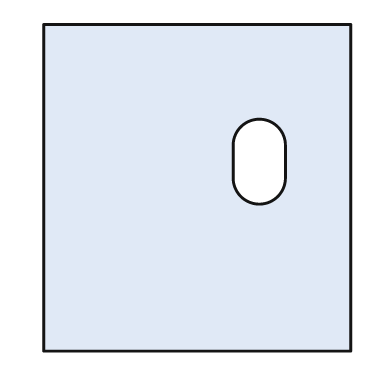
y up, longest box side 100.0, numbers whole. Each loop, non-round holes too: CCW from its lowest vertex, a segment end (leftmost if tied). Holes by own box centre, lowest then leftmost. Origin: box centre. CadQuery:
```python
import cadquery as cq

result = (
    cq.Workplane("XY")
    .moveTo(-47.0, -50.0)
    .lineTo(47.0, -50.0)
    .lineTo(47.0, 50.0)
    .lineTo(-47.0, 50.0)
    .close()
    .moveTo(11.0, 3.0)
    .threePointArc((19.0, -5.0), (27.0, 3.0))
    .lineTo(27.0, 13.0)
    .threePointArc((19.0, 21.0), (11.0, 13.0))
    .close()
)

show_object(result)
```